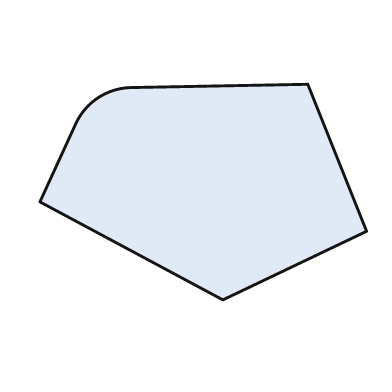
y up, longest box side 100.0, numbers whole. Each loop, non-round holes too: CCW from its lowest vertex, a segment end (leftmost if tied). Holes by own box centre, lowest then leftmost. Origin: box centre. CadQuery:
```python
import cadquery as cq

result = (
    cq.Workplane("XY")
    .moveTo(6.0, -33.0)
    .lineTo(50.0, -12.0)
    .lineTo(32.0, 33.0)
    .lineTo(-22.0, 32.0)
    .threePointArc((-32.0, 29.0), (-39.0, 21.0))
    .lineTo(-50.0, -3.0)
    .close()
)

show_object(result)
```